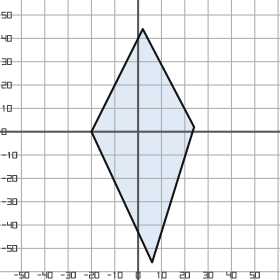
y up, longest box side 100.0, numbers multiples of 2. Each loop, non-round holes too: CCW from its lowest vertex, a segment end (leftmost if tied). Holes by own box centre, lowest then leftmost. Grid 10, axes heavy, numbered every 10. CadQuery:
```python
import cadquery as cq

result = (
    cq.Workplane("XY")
    .moveTo(6.0, -56.0)
    .lineTo(24.0, 2.0)
    .lineTo(2.0, 44.0)
    .lineTo(-20.0, 0.0)
    .close()
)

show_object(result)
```